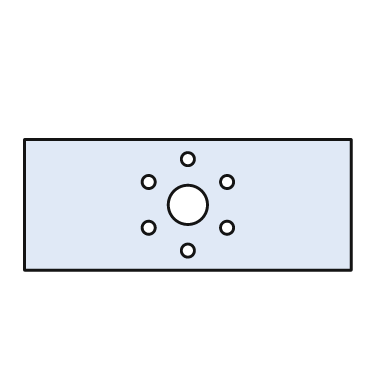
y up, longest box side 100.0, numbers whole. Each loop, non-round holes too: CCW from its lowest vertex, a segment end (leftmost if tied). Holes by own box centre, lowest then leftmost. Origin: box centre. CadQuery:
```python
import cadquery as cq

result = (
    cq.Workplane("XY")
    .moveTo(-50.0, -20.0)
    .lineTo(50.0, -20.0)
    .lineTo(50.0, 20.0)
    .lineTo(-50.0, 20.0)
    .close()
    .moveTo(0.0, -14.0)
    .circle(2.0)
    .moveTo(-12.0, -7.0)
    .circle(2.0)
    .moveTo(12.0, -7.0)
    .circle(2.0)
    .moveTo(0.0, 0.0)
    .circle(6.0)
    .moveTo(-12.0, 7.0)
    .circle(2.0)
    .moveTo(12.0, 7.0)
    .circle(2.0)
    .moveTo(0.0, 14.0)
    .circle(2.0)
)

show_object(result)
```